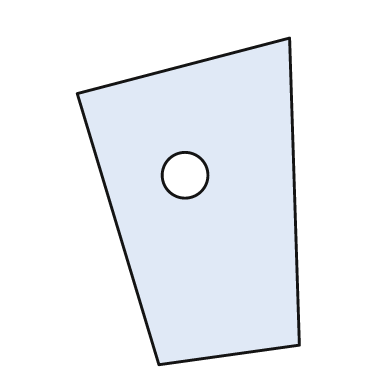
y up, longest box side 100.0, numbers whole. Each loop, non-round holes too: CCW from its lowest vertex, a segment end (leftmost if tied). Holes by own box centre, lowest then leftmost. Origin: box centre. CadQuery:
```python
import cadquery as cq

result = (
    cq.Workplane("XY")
    .moveTo(-9.0, -50.0)
    .lineTo(34.0, -44.0)
    .lineTo(31.0, 50.0)
    .lineTo(-34.0, 33.0)
    .close()
    .moveTo(-1.0, 8.0)
    .circle(7.0)
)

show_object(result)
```